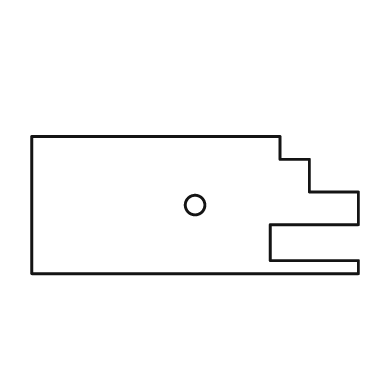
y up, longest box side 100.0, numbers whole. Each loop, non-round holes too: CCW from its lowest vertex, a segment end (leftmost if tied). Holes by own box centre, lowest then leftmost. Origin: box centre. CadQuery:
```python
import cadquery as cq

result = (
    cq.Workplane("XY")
    .moveTo(-50.0, -21.0)
    .lineTo(50.0, -21.0)
    .lineTo(50.0, -17.0)
    .lineTo(23.0, -17.0)
    .lineTo(23.0, -6.0)
    .lineTo(50.0, -6.0)
    .lineTo(50.0, 4.0)
    .lineTo(35.0, 4.0)
    .lineTo(35.0, 14.0)
    .lineTo(26.0, 14.0)
    .lineTo(26.0, 21.0)
    .lineTo(-50.0, 21.0)
    .close()
    .moveTo(0.0, 0.0)
    .circle(3.0)
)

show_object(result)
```